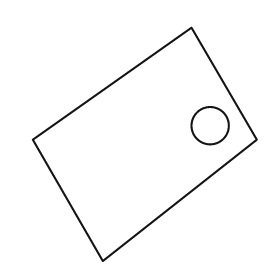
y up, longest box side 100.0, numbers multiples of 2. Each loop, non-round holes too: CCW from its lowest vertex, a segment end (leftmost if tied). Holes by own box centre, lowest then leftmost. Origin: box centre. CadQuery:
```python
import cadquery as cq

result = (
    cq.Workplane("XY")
    .moveTo(-18.0, -50.0)
    .lineTo(48.0, 2.0)
    .lineTo(20.0, 50.0)
    .lineTo(-48.0, 2.0)
    .close()
    .moveTo(28.0, 8.0)
    .circle(8.0)
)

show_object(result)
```